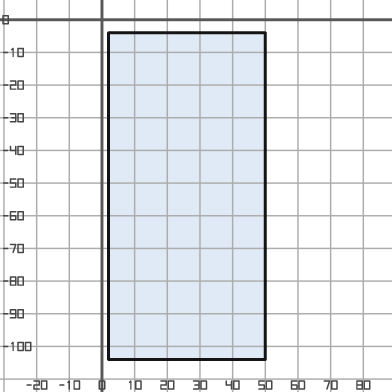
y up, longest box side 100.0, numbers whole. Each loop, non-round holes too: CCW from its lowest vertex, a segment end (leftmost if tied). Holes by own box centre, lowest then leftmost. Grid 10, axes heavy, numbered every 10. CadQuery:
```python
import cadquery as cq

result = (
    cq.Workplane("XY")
    .moveTo(2.0, -104.0)
    .lineTo(50.0, -104.0)
    .lineTo(50.0, -4.0)
    .lineTo(2.0, -4.0)
    .close()
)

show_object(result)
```